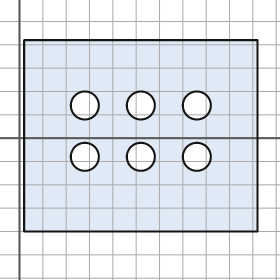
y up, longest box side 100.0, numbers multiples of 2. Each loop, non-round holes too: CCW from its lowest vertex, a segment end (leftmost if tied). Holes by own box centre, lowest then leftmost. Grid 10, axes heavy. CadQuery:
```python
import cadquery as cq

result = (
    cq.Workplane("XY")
    .moveTo(2.0, -40.0)
    .lineTo(102.0, -40.0)
    .lineTo(102.0, 42.0)
    .lineTo(2.0, 42.0)
    .close()
    .moveTo(28.0, -8.0)
    .circle(6.0)
    .moveTo(52.0, -8.0)
    .circle(6.0)
    .moveTo(76.0, -8.0)
    .circle(6.0)
    .moveTo(28.0, 14.0)
    .circle(6.0)
    .moveTo(52.0, 14.0)
    .circle(6.0)
    .moveTo(76.0, 14.0)
    .circle(6.0)
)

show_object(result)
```